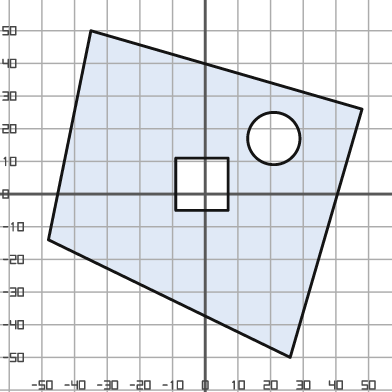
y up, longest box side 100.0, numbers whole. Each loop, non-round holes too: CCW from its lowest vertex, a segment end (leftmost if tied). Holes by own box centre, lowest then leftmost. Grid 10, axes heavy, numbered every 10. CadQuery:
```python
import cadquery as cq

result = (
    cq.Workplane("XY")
    .moveTo(26.0, -50.0)
    .lineTo(48.0, 26.0)
    .lineTo(-35.0, 50.0)
    .lineTo(-48.0, -14.0)
    .close()
    .moveTo(-9.0, -5.0)
    .lineTo(7.0, -5.0)
    .lineTo(7.0, 11.0)
    .lineTo(-9.0, 11.0)
    .close()
    .moveTo(21.0, 17.0)
    .circle(8.0)
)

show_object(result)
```